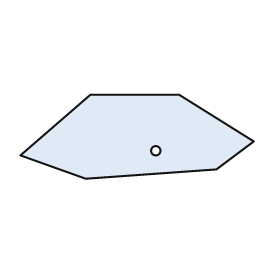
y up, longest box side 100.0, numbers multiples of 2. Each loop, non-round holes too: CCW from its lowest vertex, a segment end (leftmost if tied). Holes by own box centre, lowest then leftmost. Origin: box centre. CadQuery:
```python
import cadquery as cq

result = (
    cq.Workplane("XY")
    .moveTo(-22.0, -18.0)
    .lineTo(34.0, -14.0)
    .lineTo(50.0, -2.0)
    .lineTo(18.0, 18.0)
    .lineTo(-20.0, 18.0)
    .lineTo(-50.0, -8.0)
    .close()
    .moveTo(8.0, -6.0)
    .circle(2.0)
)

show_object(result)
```